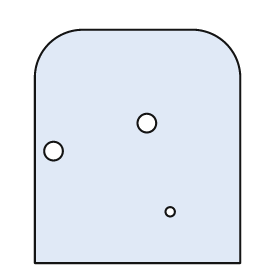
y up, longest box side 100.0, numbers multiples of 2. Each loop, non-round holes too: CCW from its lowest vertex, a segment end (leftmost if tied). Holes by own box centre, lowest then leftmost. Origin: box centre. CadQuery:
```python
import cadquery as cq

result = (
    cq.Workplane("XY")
    .moveTo(-44.0, -50.0)
    .lineTo(44.0, -50.0)
    .lineTo(44.0, 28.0)
    .threePointArc((38.0, 44.0), (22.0, 50.0))
    .lineTo(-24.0, 50.0)
    .threePointArc((-38.0, 44.0), (-44.0, 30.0))
    .close()
    .moveTo(14.0, -28.0)
    .circle(2.0)
    .moveTo(-36.0, -2.0)
    .circle(4.0)
    .moveTo(4.0, 10.0)
    .circle(4.0)
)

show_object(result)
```